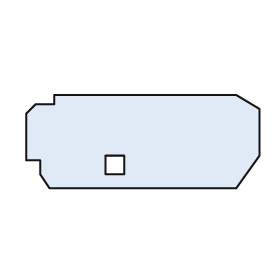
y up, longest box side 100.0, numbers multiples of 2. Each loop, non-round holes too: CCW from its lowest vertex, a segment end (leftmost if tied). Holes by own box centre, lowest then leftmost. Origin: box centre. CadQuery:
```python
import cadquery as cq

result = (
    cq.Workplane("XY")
    .moveTo(-40.0, -20.0)
    .lineTo(40.0, -20.0)
    .lineTo(50.0, -6.0)
    .lineTo(50.0, 14.0)
    .lineTo(40.0, 20.0)
    .lineTo(-38.0, 20.0)
    .lineTo(-38.0, 16.0)
    .lineTo(-46.0, 16.0)
    .lineTo(-50.0, 12.0)
    .lineTo(-50.0, -8.0)
    .lineTo(-44.0, -8.0)
    .lineTo(-44.0, -14.0)
    .close()
    .moveTo(-16.0, -14.0)
    .lineTo(-8.0, -14.0)
    .lineTo(-8.0, -6.0)
    .lineTo(-16.0, -6.0)
    .close()
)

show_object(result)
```